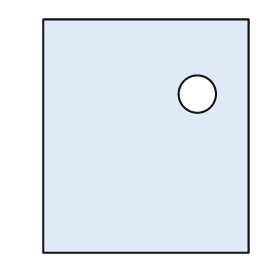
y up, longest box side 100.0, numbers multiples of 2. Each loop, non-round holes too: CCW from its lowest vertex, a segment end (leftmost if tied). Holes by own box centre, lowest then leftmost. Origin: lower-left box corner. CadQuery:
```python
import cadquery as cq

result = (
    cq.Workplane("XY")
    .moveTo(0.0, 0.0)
    .lineTo(88.0, 0.0)
    .lineTo(88.0, 100.0)
    .lineTo(0.0, 100.0)
    .close()
    .moveTo(66.0, 68.0)
    .circle(8.0)
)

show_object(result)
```